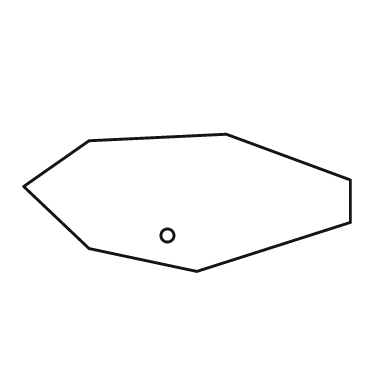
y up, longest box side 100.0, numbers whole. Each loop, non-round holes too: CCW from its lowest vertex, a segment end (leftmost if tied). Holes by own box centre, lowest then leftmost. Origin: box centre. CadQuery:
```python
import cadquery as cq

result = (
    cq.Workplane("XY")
    .moveTo(3.0, -21.0)
    .lineTo(50.0, -6.0)
    .lineTo(50.0, 7.0)
    .lineTo(12.0, 21.0)
    .lineTo(-30.0, 19.0)
    .lineTo(-50.0, 5.0)
    .lineTo(-30.0, -14.0)
    .close()
    .moveTo(-6.0, -10.0)
    .circle(2.0)
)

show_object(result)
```